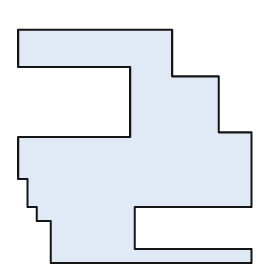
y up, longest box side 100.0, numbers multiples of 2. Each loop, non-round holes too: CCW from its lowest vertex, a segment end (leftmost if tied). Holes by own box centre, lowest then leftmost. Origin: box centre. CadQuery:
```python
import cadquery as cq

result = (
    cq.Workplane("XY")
    .moveTo(-36.0, -50.0)
    .lineTo(50.0, -50.0)
    .lineTo(50.0, -44.0)
    .lineTo(0.0, -44.0)
    .lineTo(0.0, -26.0)
    .lineTo(50.0, -26.0)
    .lineTo(50.0, 6.0)
    .lineTo(36.0, 6.0)
    .lineTo(36.0, 30.0)
    .lineTo(16.0, 30.0)
    .lineTo(16.0, 50.0)
    .lineTo(-50.0, 50.0)
    .lineTo(-50.0, 34.0)
    .lineTo(-2.0, 34.0)
    .lineTo(-2.0, 4.0)
    .lineTo(-50.0, 4.0)
    .lineTo(-50.0, -14.0)
    .lineTo(-46.0, -14.0)
    .lineTo(-46.0, -26.0)
    .lineTo(-42.0, -26.0)
    .lineTo(-42.0, -32.0)
    .lineTo(-36.0, -32.0)
    .close()
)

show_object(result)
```